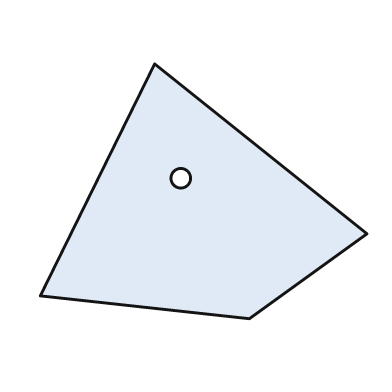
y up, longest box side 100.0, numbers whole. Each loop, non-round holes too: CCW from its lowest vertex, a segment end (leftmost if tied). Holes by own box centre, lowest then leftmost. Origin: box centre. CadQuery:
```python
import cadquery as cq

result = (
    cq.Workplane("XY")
    .moveTo(14.0, -39.0)
    .lineTo(50.0, -13.0)
    .lineTo(-15.0, 39.0)
    .lineTo(-50.0, -32.0)
    .close()
    .moveTo(-7.0, 4.0)
    .circle(3.0)
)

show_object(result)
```